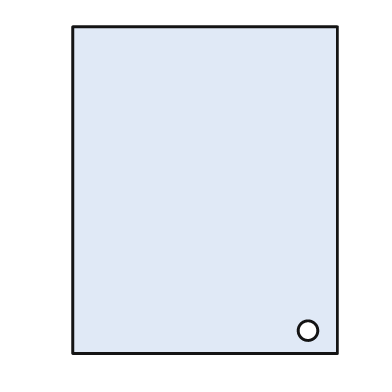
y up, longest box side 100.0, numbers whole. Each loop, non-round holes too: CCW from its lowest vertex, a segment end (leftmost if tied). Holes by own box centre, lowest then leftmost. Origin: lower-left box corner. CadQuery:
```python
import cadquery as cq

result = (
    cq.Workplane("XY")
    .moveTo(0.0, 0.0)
    .lineTo(81.0, 0.0)
    .lineTo(81.0, 100.0)
    .lineTo(0.0, 100.0)
    .close()
    .moveTo(72.0, 7.0)
    .circle(3.0)
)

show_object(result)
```